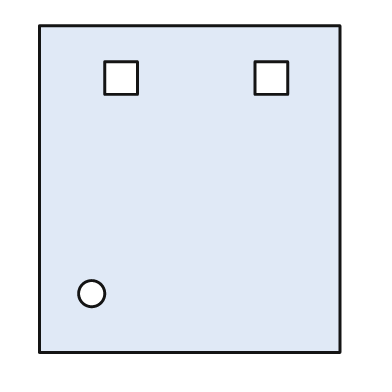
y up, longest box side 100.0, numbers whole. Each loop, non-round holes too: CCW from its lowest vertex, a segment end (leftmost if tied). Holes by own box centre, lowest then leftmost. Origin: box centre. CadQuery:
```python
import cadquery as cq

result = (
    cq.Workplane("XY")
    .moveTo(-46.0, -50.0)
    .lineTo(46.0, -50.0)
    .lineTo(46.0, 50.0)
    .lineTo(-46.0, 50.0)
    .close()
    .moveTo(-30.0, -32.0)
    .circle(4.0)
    .moveTo(-26.0, 29.0)
    .lineTo(-16.0, 29.0)
    .lineTo(-16.0, 39.0)
    .lineTo(-26.0, 39.0)
    .close()
    .moveTo(20.0, 29.0)
    .lineTo(30.0, 29.0)
    .lineTo(30.0, 39.0)
    .lineTo(20.0, 39.0)
    .close()
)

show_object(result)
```